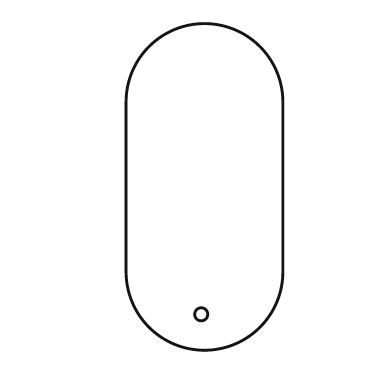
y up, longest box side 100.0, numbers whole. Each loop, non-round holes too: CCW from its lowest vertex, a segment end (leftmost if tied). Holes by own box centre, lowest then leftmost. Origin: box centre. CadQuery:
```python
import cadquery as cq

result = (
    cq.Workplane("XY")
    .moveTo(-24.0, -26.0)
    .threePointArc((0.0, -50.0), (24.0, -26.0))
    .lineTo(24.0, 26.0)
    .threePointArc((0.0, 50.0), (-24.0, 26.0))
    .close()
    .moveTo(-1.0, -39.0)
    .circle(2.0)
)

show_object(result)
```